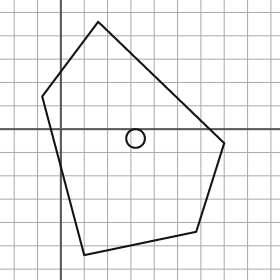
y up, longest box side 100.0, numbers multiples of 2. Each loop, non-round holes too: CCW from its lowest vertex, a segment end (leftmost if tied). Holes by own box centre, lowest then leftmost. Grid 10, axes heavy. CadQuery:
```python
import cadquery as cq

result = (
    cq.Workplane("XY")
    .moveTo(10.0, -54.0)
    .lineTo(58.0, -44.0)
    .lineTo(70.0, -6.0)
    .lineTo(16.0, 46.0)
    .lineTo(-8.0, 14.0)
    .close()
    .moveTo(32.0, -4.0)
    .circle(4.0)
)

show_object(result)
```